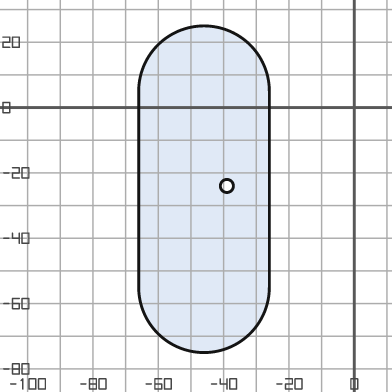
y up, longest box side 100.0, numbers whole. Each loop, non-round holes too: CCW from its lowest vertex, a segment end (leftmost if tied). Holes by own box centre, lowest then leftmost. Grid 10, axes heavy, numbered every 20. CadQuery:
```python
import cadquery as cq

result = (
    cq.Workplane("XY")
    .moveTo(-66.0, -55.0)
    .threePointArc((-46.0, -75.0), (-26.0, -55.0))
    .lineTo(-26.0, 5.0)
    .threePointArc((-46.0, 25.0), (-66.0, 5.0))
    .close()
    .moveTo(-39.0, -24.0)
    .circle(2.0)
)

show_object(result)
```